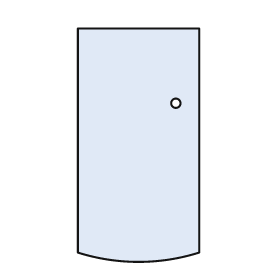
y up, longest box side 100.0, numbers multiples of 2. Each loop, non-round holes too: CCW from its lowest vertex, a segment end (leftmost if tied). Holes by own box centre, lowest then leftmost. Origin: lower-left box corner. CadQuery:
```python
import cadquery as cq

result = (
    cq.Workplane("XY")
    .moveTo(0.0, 4.0)
    .threePointArc((26.0, 0.0), (52.0, 4.0))
    .lineTo(52.0, 100.0)
    .lineTo(0.0, 100.0)
    .close()
    .moveTo(42.0, 68.0)
    .circle(2.0)
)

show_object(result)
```